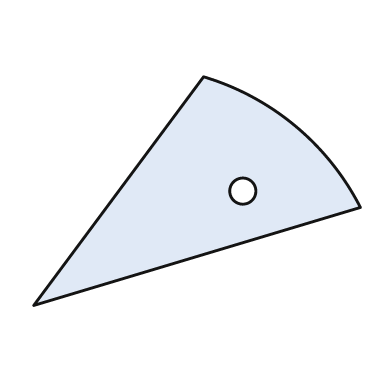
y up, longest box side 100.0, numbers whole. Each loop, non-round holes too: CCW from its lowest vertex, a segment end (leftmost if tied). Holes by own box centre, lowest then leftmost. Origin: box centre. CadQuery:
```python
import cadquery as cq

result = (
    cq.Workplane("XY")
    .moveTo(-50.0, -35.0)
    .lineTo(50.0, -5.0)
    .threePointArc((30.0, 20.0), (2.0, 35.0))
    .close()
    .moveTo(14.0, 0.0)
    .circle(4.0)
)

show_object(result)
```